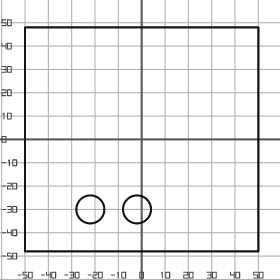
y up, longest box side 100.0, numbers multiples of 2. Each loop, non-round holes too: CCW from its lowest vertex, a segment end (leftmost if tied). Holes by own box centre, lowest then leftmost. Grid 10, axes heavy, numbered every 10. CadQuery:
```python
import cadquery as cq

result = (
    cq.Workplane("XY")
    .moveTo(-50.0, -48.0)
    .lineTo(50.0, -48.0)
    .lineTo(50.0, 48.0)
    .lineTo(-50.0, 48.0)
    .close()
    .moveTo(-22.0, -30.0)
    .circle(6.0)
    .moveTo(-2.0, -30.0)
    .circle(6.0)
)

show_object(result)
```